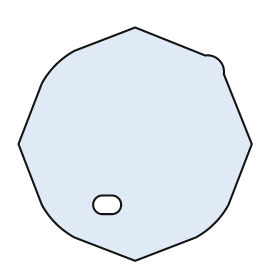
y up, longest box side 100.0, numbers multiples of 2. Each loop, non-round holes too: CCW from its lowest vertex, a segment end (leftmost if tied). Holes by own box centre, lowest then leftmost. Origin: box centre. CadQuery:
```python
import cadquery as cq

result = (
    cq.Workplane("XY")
    .moveTo(0.0, -50.0)
    .lineTo(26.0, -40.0)
    .threePointArc((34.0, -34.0), (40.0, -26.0))
    .lineTo(50.0, 0.0)
    .lineTo(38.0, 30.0)
    .threePointArc((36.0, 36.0), (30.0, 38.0))
    .lineTo(0.0, 50.0)
    .lineTo(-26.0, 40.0)
    .threePointArc((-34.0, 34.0), (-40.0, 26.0))
    .lineTo(-50.0, 0.0)
    .lineTo(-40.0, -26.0)
    .threePointArc((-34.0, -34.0), (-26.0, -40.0))
    .close()
    .moveTo(-14.0, -30.0)
    .lineTo(-10.0, -30.0)
    .threePointArc((-6.0, -26.0), (-10.0, -22.0))
    .lineTo(-14.0, -22.0)
    .threePointArc((-18.0, -26.0), (-14.0, -30.0))
    .close()
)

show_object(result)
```